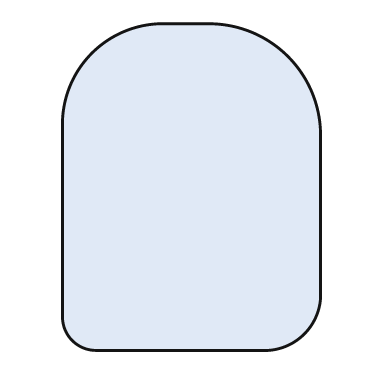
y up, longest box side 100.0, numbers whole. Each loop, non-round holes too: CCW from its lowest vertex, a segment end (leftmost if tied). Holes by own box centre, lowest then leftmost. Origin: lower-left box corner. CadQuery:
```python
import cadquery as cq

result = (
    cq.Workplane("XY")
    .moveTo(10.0, 0.0)
    .lineTo(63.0, 0.0)
    .threePointArc((74.0, 5.0), (79.0, 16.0))
    .lineTo(79.0, 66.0)
    .threePointArc((69.0, 90.0), (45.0, 100.0))
    .lineTo(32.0, 100.0)
    .threePointArc((9.0, 91.0), (0.0, 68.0))
    .lineTo(0.0, 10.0)
    .threePointArc((3.0, 3.0), (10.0, 0.0))
    .close()
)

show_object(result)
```